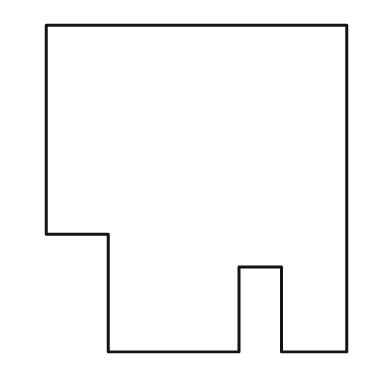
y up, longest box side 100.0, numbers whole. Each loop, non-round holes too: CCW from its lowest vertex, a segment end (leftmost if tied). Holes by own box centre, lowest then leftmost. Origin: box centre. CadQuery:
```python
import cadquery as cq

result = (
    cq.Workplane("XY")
    .moveTo(-27.0, -50.0)
    .lineTo(13.0, -50.0)
    .lineTo(13.0, -24.0)
    .lineTo(26.0, -24.0)
    .lineTo(26.0, -50.0)
    .lineTo(46.0, -50.0)
    .lineTo(46.0, 50.0)
    .lineTo(-46.0, 50.0)
    .lineTo(-46.0, -14.0)
    .lineTo(-27.0, -14.0)
    .close()
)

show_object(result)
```